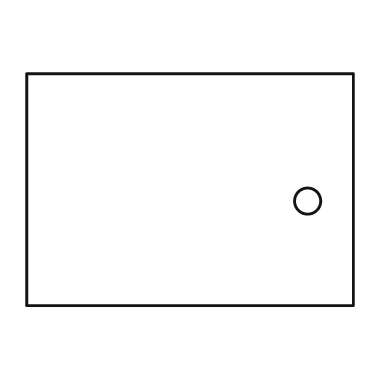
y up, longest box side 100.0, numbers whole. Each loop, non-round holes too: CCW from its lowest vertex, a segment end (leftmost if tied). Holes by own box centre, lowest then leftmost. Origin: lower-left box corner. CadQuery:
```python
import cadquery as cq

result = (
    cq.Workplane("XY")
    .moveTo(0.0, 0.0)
    .lineTo(100.0, 0.0)
    .lineTo(100.0, 71.0)
    .lineTo(0.0, 71.0)
    .close()
    .moveTo(86.0, 32.0)
    .circle(4.0)
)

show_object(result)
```